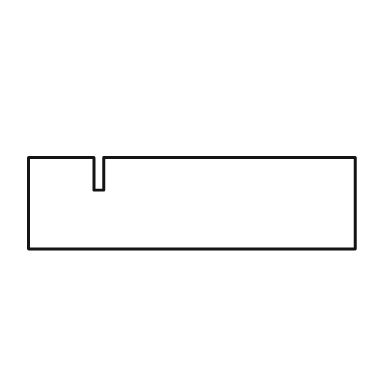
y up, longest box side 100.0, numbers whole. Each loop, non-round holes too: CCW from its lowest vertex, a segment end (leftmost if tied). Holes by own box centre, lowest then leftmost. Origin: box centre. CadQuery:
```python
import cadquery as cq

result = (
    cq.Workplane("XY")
    .moveTo(-50.0, -14.0)
    .lineTo(50.0, -14.0)
    .lineTo(50.0, 14.0)
    .lineTo(-27.0, 14.0)
    .lineTo(-27.0, 4.0)
    .lineTo(-30.0, 4.0)
    .lineTo(-30.0, 14.0)
    .lineTo(-50.0, 14.0)
    .close()
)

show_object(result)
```